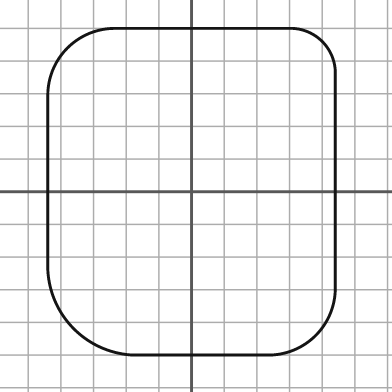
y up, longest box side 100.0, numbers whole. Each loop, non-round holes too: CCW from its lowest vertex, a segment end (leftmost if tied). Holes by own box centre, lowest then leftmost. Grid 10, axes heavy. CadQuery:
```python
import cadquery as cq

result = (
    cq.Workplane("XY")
    .moveTo(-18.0, -50.0)
    .lineTo(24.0, -50.0)
    .threePointArc((38.0, -44.0), (44.0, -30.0))
    .lineTo(44.0, 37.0)
    .threePointArc((40.0, 46.0), (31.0, 50.0))
    .lineTo(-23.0, 50.0)
    .threePointArc((-38.0, 44.0), (-44.0, 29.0))
    .lineTo(-44.0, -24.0)
    .threePointArc((-36.0, -42.0), (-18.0, -50.0))
    .close()
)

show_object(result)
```